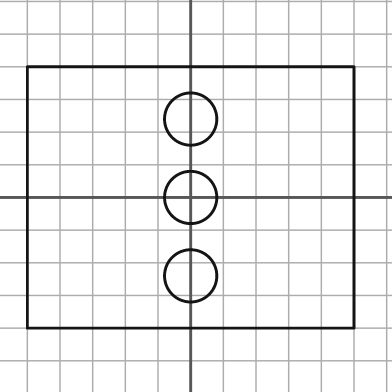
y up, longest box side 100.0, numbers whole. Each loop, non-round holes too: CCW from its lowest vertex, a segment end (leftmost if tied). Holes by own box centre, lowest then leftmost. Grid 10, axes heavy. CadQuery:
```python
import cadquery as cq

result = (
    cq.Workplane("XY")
    .moveTo(-50.0, -40.0)
    .lineTo(50.0, -40.0)
    .lineTo(50.0, 40.0)
    .lineTo(-50.0, 40.0)
    .close()
    .moveTo(0.0, -24.0)
    .circle(8.0)
    .moveTo(0.0, 0.0)
    .circle(8.0)
    .moveTo(0.0, 24.0)
    .circle(8.0)
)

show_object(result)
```